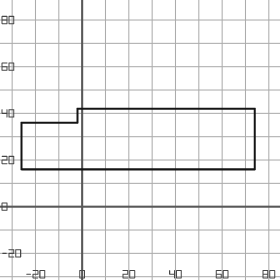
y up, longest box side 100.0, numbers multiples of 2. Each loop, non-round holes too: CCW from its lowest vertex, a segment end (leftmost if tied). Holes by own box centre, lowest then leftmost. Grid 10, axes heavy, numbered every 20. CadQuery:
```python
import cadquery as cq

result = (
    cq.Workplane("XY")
    .moveTo(-26.0, 16.0)
    .lineTo(74.0, 16.0)
    .lineTo(74.0, 42.0)
    .lineTo(-2.0, 42.0)
    .lineTo(-2.0, 36.0)
    .lineTo(-26.0, 36.0)
    .close()
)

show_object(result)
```